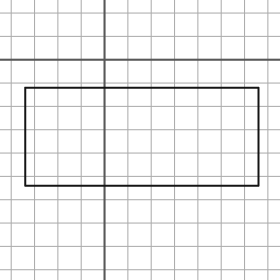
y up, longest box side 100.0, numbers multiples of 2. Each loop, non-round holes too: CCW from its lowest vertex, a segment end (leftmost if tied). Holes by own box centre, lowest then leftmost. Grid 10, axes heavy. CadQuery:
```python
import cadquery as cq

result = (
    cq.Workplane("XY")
    .moveTo(-34.0, -54.0)
    .lineTo(66.0, -54.0)
    .lineTo(66.0, -12.0)
    .lineTo(-34.0, -12.0)
    .close()
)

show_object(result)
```